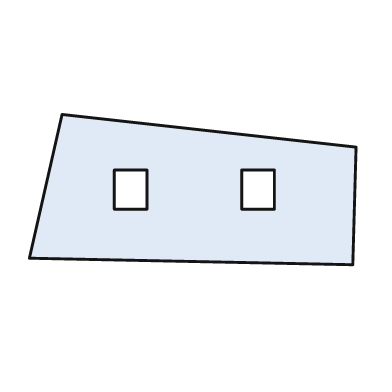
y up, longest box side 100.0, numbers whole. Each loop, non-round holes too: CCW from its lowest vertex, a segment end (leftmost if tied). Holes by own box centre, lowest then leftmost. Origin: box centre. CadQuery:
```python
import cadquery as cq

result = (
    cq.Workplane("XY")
    .moveTo(49.0, -23.0)
    .lineTo(50.0, 13.0)
    .lineTo(-40.0, 23.0)
    .lineTo(-50.0, -21.0)
    .close()
    .moveTo(-24.0, -6.0)
    .lineTo(-14.0, -6.0)
    .lineTo(-14.0, 6.0)
    .lineTo(-24.0, 6.0)
    .close()
    .moveTo(15.0, -6.0)
    .lineTo(25.0, -6.0)
    .lineTo(25.0, 6.0)
    .lineTo(15.0, 6.0)
    .close()
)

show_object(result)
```